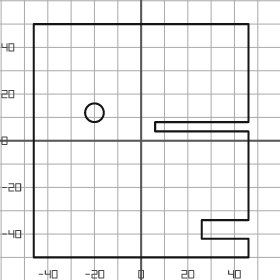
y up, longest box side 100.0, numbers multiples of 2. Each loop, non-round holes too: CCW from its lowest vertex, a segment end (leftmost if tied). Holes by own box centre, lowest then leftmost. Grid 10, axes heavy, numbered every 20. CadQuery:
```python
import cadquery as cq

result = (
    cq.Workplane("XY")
    .moveTo(-46.0, -50.0)
    .lineTo(46.0, -50.0)
    .lineTo(46.0, -42.0)
    .lineTo(26.0, -42.0)
    .lineTo(26.0, -34.0)
    .lineTo(46.0, -34.0)
    .lineTo(46.0, 4.0)
    .lineTo(6.0, 4.0)
    .lineTo(6.0, 8.0)
    .lineTo(46.0, 8.0)
    .lineTo(46.0, 50.0)
    .lineTo(-46.0, 50.0)
    .close()
    .moveTo(-20.0, 12.0)
    .circle(4.0)
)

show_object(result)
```